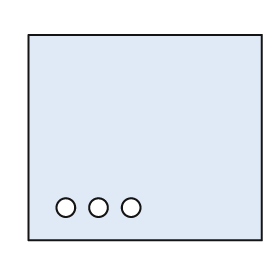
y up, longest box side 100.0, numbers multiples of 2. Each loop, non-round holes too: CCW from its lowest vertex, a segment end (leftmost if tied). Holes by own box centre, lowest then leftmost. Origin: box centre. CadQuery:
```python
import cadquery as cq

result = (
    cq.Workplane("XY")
    .moveTo(-50.0, -44.0)
    .lineTo(50.0, -44.0)
    .lineTo(50.0, 44.0)
    .lineTo(-50.0, 44.0)
    .close()
    .moveTo(-34.0, -30.0)
    .circle(4.0)
    .moveTo(-20.0, -30.0)
    .circle(4.0)
    .moveTo(-6.0, -30.0)
    .circle(4.0)
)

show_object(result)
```